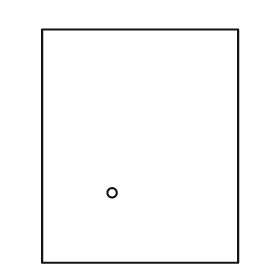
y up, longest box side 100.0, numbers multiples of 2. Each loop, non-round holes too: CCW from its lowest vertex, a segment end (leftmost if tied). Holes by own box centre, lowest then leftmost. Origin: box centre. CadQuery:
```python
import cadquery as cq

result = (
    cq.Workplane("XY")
    .moveTo(-42.0, -50.0)
    .lineTo(42.0, -50.0)
    .lineTo(42.0, 50.0)
    .lineTo(-42.0, 50.0)
    .close()
    .moveTo(-12.0, -20.0)
    .circle(2.0)
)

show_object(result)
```